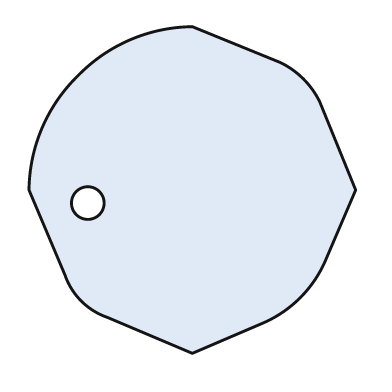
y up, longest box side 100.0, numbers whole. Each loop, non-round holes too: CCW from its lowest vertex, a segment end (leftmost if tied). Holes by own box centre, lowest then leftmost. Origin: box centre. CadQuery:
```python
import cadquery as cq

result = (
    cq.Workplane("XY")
    .moveTo(0.0, -50.0)
    .lineTo(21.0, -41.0)
    .threePointArc((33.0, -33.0), (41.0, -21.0))
    .lineTo(50.0, 0.0)
    .lineTo(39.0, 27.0)
    .threePointArc((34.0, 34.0), (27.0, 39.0))
    .lineTo(0.0, 50.0)
    .threePointArc((-19.0, 46.0), (-35.0, 35.0))
    .threePointArc((-46.0, 19.0), (-50.0, 0.0))
    .lineTo(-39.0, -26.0)
    .threePointArc((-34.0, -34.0), (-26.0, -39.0))
    .close()
    .moveTo(-32.0, -4.0)
    .circle(5.0)
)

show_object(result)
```